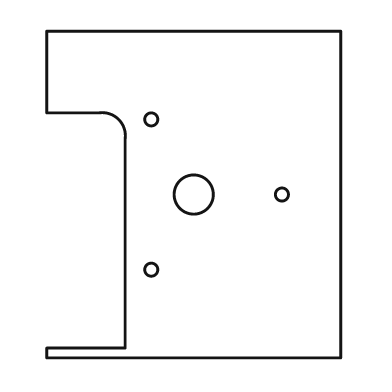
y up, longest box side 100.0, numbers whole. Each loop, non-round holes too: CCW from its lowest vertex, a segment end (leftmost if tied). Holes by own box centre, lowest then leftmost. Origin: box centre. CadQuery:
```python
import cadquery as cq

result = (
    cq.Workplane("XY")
    .moveTo(-45.0, -50.0)
    .lineTo(45.0, -50.0)
    .lineTo(45.0, 50.0)
    .lineTo(-45.0, 50.0)
    .lineTo(-45.0, 25.0)
    .lineTo(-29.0, 25.0)
    .threePointArc((-23.0, 23.0), (-21.0, 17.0))
    .lineTo(-21.0, -47.0)
    .lineTo(-45.0, -47.0)
    .close()
    .moveTo(-13.0, -23.0)
    .circle(2.0)
    .moveTo(0.0, 0.0)
    .circle(6.0)
    .moveTo(27.0, 0.0)
    .circle(2.0)
    .moveTo(-13.0, 23.0)
    .circle(2.0)
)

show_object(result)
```